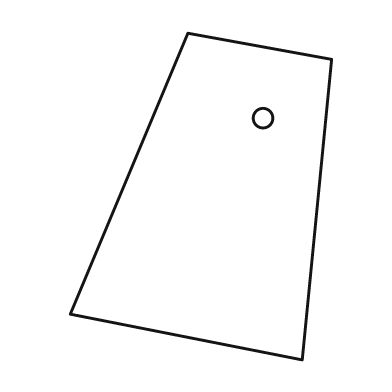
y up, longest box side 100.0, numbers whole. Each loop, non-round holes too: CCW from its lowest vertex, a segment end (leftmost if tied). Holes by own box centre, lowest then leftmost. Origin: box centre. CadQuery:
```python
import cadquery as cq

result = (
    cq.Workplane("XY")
    .moveTo(31.0, -50.0)
    .lineTo(40.0, 42.0)
    .lineTo(-4.0, 50.0)
    .lineTo(-40.0, -36.0)
    .close()
    .moveTo(19.0, 24.0)
    .circle(3.0)
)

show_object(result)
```